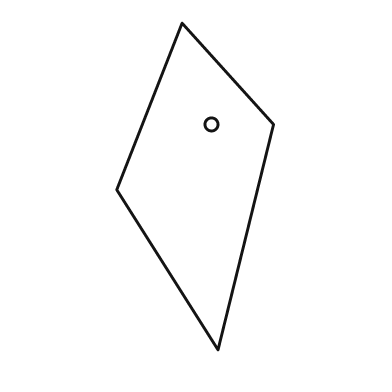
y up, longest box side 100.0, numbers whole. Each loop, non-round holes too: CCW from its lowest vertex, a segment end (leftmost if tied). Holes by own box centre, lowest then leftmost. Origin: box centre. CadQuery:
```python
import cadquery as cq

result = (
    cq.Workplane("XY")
    .moveTo(7.0, -50.0)
    .lineTo(24.0, 19.0)
    .lineTo(-4.0, 50.0)
    .lineTo(-24.0, -1.0)
    .close()
    .moveTo(5.0, 19.0)
    .circle(2.0)
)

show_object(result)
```